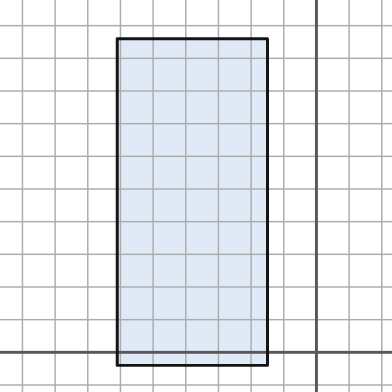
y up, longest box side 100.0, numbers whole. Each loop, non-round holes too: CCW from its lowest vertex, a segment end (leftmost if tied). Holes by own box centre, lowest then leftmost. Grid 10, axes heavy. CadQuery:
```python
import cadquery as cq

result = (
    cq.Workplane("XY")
    .moveTo(-61.0, -4.0)
    .lineTo(-15.0, -4.0)
    .lineTo(-15.0, 96.0)
    .lineTo(-61.0, 96.0)
    .close()
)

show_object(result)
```